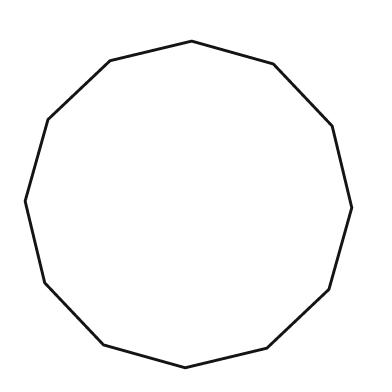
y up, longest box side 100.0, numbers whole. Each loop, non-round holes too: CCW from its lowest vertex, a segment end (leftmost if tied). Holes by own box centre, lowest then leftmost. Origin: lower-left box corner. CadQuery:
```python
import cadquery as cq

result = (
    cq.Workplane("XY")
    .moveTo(49.0, 0.0)
    .lineTo(74.0, 6.0)
    .lineTo(93.0, 24.0)
    .lineTo(100.0, 49.0)
    .lineTo(94.0, 74.0)
    .lineTo(76.0, 93.0)
    .lineTo(51.0, 100.0)
    .lineTo(26.0, 94.0)
    .lineTo(7.0, 76.0)
    .lineTo(0.0, 51.0)
    .lineTo(6.0, 26.0)
    .lineTo(24.0, 7.0)
    .close()
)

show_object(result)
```